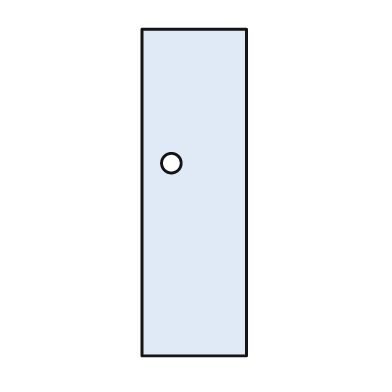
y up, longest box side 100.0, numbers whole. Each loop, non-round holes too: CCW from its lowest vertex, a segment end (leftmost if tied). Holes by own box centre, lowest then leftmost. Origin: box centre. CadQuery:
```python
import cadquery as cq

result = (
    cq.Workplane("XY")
    .moveTo(-16.0, -50.0)
    .lineTo(16.0, -50.0)
    .lineTo(16.0, 50.0)
    .lineTo(-16.0, 50.0)
    .close()
    .moveTo(-7.0, 9.0)
    .circle(3.0)
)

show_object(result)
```